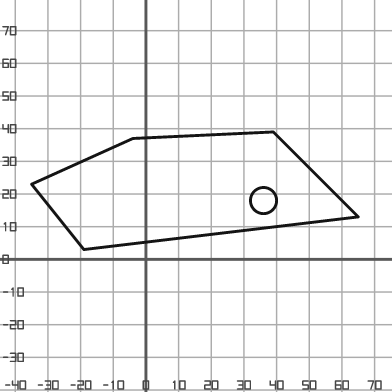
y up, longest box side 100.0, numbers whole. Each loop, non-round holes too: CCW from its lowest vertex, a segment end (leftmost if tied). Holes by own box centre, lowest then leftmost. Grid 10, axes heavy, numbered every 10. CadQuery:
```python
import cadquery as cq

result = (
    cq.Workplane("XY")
    .moveTo(-19.0, 3.0)
    .lineTo(65.0, 13.0)
    .lineTo(39.0, 39.0)
    .lineTo(-4.0, 37.0)
    .lineTo(-35.0, 23.0)
    .close()
    .moveTo(36.0, 18.0)
    .circle(4.0)
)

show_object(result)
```